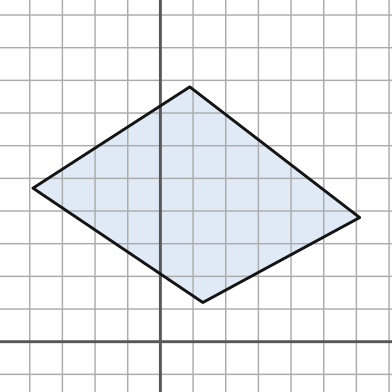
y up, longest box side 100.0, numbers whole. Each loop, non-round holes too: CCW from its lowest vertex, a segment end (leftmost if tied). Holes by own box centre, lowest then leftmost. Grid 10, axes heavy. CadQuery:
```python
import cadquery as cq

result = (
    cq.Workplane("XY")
    .moveTo(13.0, 12.0)
    .lineTo(61.0, 38.0)
    .lineTo(9.0, 78.0)
    .lineTo(-39.0, 47.0)
    .close()
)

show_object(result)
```